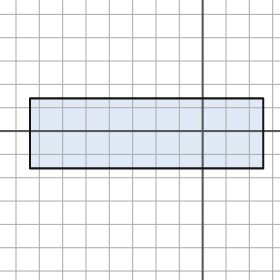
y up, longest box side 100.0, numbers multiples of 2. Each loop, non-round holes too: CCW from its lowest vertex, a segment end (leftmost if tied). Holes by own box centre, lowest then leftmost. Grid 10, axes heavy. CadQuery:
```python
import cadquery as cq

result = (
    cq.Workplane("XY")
    .moveTo(-74.0, -16.0)
    .lineTo(26.0, -16.0)
    .lineTo(26.0, 14.0)
    .lineTo(-74.0, 14.0)
    .close()
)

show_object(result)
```